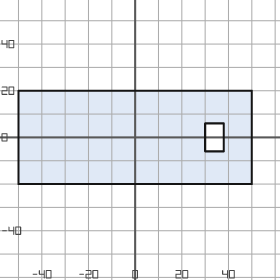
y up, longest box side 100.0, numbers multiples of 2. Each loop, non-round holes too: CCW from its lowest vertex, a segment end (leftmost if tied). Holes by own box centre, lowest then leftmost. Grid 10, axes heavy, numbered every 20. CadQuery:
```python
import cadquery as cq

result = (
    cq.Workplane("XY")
    .moveTo(-50.0, -20.0)
    .lineTo(50.0, -20.0)
    .lineTo(50.0, 20.0)
    .lineTo(-50.0, 20.0)
    .close()
    .moveTo(30.0, -6.0)
    .lineTo(38.0, -6.0)
    .lineTo(38.0, 6.0)
    .lineTo(30.0, 6.0)
    .close()
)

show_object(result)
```